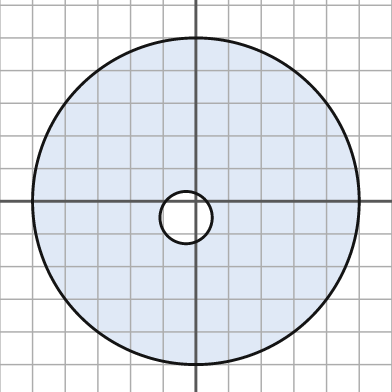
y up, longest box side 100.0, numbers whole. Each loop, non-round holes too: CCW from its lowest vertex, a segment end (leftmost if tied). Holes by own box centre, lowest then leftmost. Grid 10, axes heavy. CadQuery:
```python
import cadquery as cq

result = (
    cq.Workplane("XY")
    .moveTo(0.0, 0.0)
    .circle(50.0)
    .moveTo(-3.0, -5.0)
    .circle(8.0)
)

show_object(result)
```